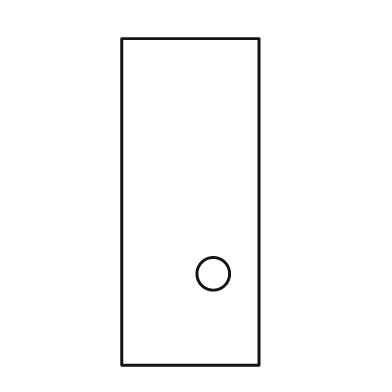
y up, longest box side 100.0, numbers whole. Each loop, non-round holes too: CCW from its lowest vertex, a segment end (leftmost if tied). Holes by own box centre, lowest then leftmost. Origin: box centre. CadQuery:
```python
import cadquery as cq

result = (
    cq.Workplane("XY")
    .moveTo(-21.0, -50.0)
    .lineTo(21.0, -50.0)
    .lineTo(21.0, 50.0)
    .lineTo(-21.0, 50.0)
    .close()
    .moveTo(7.0, -22.0)
    .circle(5.0)
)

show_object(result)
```